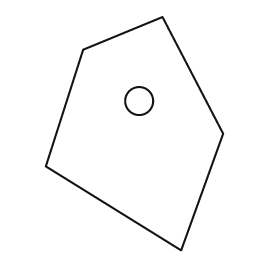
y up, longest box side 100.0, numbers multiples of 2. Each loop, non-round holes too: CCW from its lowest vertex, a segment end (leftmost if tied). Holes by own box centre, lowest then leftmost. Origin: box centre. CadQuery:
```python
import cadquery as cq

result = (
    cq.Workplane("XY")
    .moveTo(20.0, -50.0)
    .lineTo(38.0, 0.0)
    .lineTo(12.0, 50.0)
    .lineTo(-22.0, 36.0)
    .lineTo(-38.0, -14.0)
    .close()
    .moveTo(2.0, 14.0)
    .circle(6.0)
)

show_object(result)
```